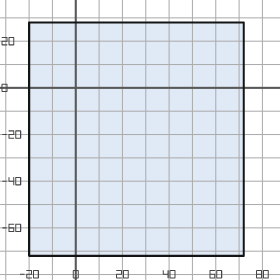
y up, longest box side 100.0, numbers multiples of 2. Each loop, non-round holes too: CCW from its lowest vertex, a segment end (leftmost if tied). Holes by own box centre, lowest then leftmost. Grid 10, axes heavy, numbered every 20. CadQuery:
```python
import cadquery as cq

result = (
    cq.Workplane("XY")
    .moveTo(-20.0, -72.0)
    .lineTo(72.0, -72.0)
    .lineTo(72.0, 28.0)
    .lineTo(-20.0, 28.0)
    .close()
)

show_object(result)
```